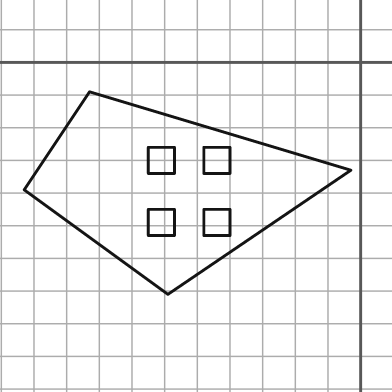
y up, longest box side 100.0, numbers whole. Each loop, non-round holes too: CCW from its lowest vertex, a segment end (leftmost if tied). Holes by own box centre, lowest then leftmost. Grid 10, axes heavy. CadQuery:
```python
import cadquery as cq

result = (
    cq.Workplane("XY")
    .moveTo(-59.0, -71.0)
    .lineTo(-3.0, -33.0)
    .lineTo(-83.0, -9.0)
    .lineTo(-103.0, -39.0)
    .close()
    .moveTo(-65.0, -53.0)
    .lineTo(-57.0, -53.0)
    .lineTo(-57.0, -45.0)
    .lineTo(-65.0, -45.0)
    .close()
    .moveTo(-48.0, -53.0)
    .lineTo(-40.0, -53.0)
    .lineTo(-40.0, -45.0)
    .lineTo(-48.0, -45.0)
    .close()
    .moveTo(-65.0, -34.0)
    .lineTo(-57.0, -34.0)
    .lineTo(-57.0, -26.0)
    .lineTo(-65.0, -26.0)
    .close()
    .moveTo(-48.0, -34.0)
    .lineTo(-40.0, -34.0)
    .lineTo(-40.0, -26.0)
    .lineTo(-48.0, -26.0)
    .close()
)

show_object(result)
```